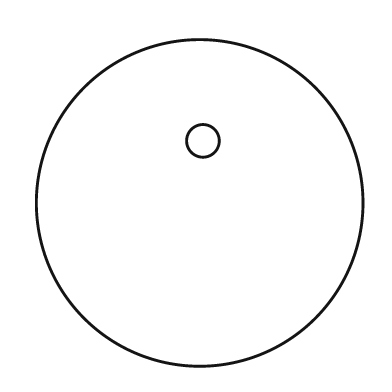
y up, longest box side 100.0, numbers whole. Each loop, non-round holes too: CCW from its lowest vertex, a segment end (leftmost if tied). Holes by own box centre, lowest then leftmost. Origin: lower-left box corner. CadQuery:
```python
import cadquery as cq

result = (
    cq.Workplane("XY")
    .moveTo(50.0, 50.0)
    .circle(50.0)
    .moveTo(51.0, 69.0)
    .circle(5.0)
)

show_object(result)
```